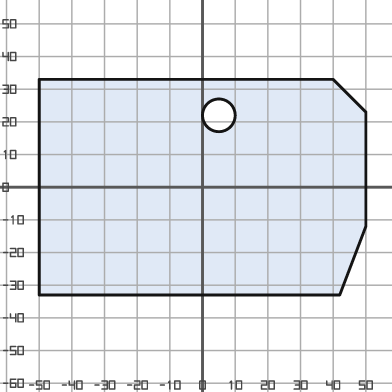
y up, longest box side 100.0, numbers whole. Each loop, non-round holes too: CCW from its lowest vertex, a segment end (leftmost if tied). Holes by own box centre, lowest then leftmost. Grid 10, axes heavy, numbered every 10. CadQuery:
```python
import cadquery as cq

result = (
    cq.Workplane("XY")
    .moveTo(-50.0, -33.0)
    .lineTo(42.0, -33.0)
    .lineTo(50.0, -12.0)
    .lineTo(50.0, 23.0)
    .lineTo(40.0, 33.0)
    .lineTo(-50.0, 33.0)
    .close()
    .moveTo(5.0, 22.0)
    .circle(5.0)
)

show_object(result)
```